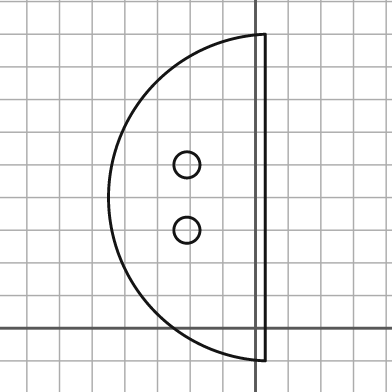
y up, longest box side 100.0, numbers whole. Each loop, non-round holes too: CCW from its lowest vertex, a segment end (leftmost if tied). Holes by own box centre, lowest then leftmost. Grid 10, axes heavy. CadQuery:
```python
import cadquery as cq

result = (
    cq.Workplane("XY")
    .moveTo(3.0, -10.0)
    .lineTo(3.0, 90.0)
    .threePointArc((-45.0, 40.0), (3.0, -10.0))
    .close()
    .moveTo(-21.0, 30.0)
    .circle(4.0)
    .moveTo(-21.0, 50.0)
    .circle(4.0)
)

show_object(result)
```